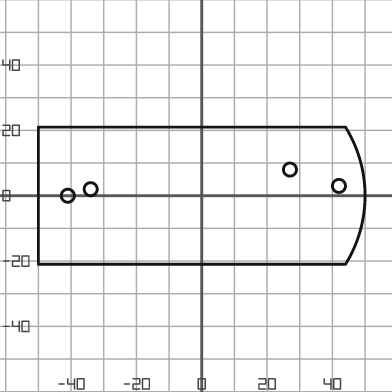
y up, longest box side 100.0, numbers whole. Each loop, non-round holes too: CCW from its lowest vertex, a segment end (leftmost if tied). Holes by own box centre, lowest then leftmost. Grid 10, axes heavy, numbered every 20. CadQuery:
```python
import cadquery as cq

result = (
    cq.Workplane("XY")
    .moveTo(-50.0, -21.0)
    .lineTo(44.0, -21.0)
    .threePointArc((50.0, 0.0), (44.0, 21.0))
    .lineTo(-50.0, 21.0)
    .close()
    .moveTo(-41.0, 0.0)
    .circle(2.0)
    .moveTo(-34.0, 2.0)
    .circle(2.0)
    .moveTo(42.0, 3.0)
    .circle(2.0)
    .moveTo(27.0, 8.0)
    .circle(2.0)
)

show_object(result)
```